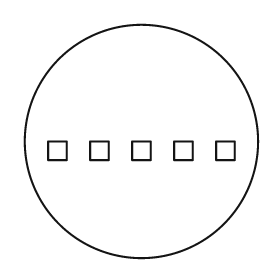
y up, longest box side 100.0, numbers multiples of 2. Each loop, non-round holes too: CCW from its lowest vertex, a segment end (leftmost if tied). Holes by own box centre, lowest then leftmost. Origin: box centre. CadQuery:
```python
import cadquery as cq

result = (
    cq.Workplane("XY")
    .moveTo(0.0, 0.0)
    .circle(50.0)
    .moveTo(-40.0, -8.0)
    .lineTo(-32.0, -8.0)
    .lineTo(-32.0, 0.0)
    .lineTo(-40.0, 0.0)
    .close()
    .moveTo(-22.0, -8.0)
    .lineTo(-14.0, -8.0)
    .lineTo(-14.0, 0.0)
    .lineTo(-22.0, 0.0)
    .close()
    .moveTo(-4.0, -8.0)
    .lineTo(4.0, -8.0)
    .lineTo(4.0, 0.0)
    .lineTo(-4.0, 0.0)
    .close()
    .moveTo(14.0, -8.0)
    .lineTo(22.0, -8.0)
    .lineTo(22.0, 0.0)
    .lineTo(14.0, 0.0)
    .close()
    .moveTo(32.0, -8.0)
    .lineTo(40.0, -8.0)
    .lineTo(40.0, 0.0)
    .lineTo(32.0, 0.0)
    .close()
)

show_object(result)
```